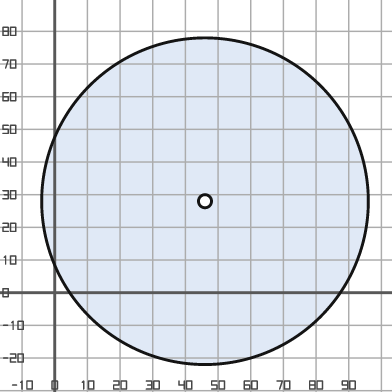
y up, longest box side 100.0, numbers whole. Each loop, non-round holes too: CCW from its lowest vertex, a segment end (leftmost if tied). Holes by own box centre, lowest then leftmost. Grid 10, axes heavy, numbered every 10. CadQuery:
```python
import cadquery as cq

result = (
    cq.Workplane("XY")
    .moveTo(46.0, 28.0)
    .circle(50.0)
    .moveTo(46.0, 28.0)
    .circle(2.0)
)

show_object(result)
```